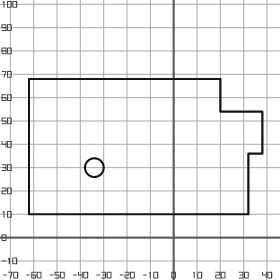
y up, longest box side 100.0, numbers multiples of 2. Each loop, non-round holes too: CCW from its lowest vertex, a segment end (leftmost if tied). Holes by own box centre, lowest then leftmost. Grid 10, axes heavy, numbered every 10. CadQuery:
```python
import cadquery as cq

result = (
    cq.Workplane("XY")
    .moveTo(-62.0, 10.0)
    .lineTo(32.0, 10.0)
    .lineTo(32.0, 36.0)
    .lineTo(38.0, 36.0)
    .lineTo(38.0, 54.0)
    .lineTo(20.0, 54.0)
    .lineTo(20.0, 68.0)
    .lineTo(-62.0, 68.0)
    .close()
    .moveTo(-34.0, 30.0)
    .circle(4.0)
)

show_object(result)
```